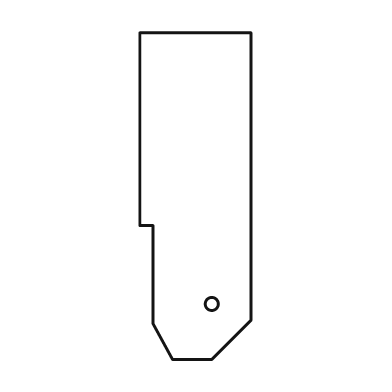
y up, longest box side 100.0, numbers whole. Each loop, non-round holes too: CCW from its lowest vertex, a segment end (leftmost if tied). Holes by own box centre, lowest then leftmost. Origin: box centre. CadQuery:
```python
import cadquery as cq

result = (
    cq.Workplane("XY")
    .moveTo(-7.0, -50.0)
    .lineTo(5.0, -50.0)
    .lineTo(17.0, -38.0)
    .lineTo(17.0, 50.0)
    .lineTo(-17.0, 50.0)
    .lineTo(-17.0, -9.0)
    .lineTo(-13.0, -9.0)
    .lineTo(-13.0, -39.0)
    .close()
    .moveTo(5.0, -33.0)
    .circle(2.0)
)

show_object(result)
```